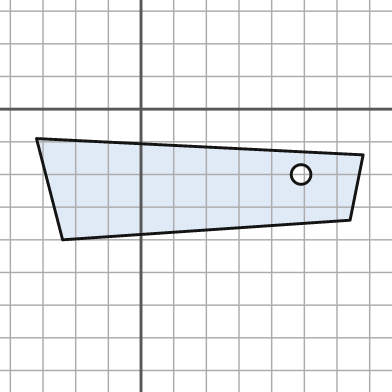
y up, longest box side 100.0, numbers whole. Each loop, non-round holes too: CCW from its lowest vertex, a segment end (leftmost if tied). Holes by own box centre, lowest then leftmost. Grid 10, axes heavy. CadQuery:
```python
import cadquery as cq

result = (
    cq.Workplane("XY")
    .moveTo(-24.0, -40.0)
    .lineTo(64.0, -34.0)
    .lineTo(68.0, -14.0)
    .lineTo(-32.0, -9.0)
    .close()
    .moveTo(49.0, -20.0)
    .circle(3.0)
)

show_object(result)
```